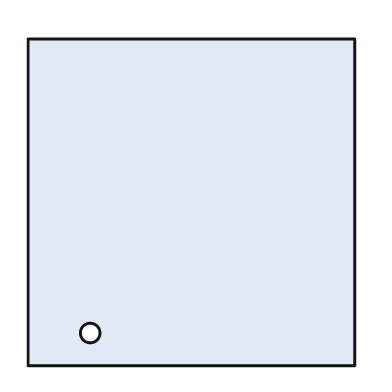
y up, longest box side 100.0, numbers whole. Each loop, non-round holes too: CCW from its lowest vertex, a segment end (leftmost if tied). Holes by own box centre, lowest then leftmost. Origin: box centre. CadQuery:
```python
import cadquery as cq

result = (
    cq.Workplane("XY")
    .moveTo(-50.0, -50.0)
    .lineTo(50.0, -50.0)
    .lineTo(50.0, 50.0)
    .lineTo(-50.0, 50.0)
    .close()
    .moveTo(-31.0, -40.0)
    .circle(3.0)
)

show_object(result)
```